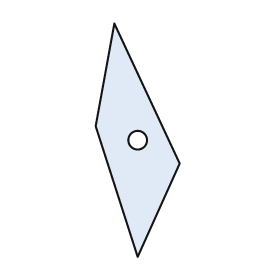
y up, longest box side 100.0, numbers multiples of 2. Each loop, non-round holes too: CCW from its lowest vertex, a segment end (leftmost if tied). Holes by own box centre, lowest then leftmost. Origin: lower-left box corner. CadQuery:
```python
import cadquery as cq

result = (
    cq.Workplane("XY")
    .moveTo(18.0, 0.0)
    .lineTo(36.0, 40.0)
    .lineTo(8.0, 100.0)
    .lineTo(0.0, 56.0)
    .close()
    .moveTo(18.0, 50.0)
    .circle(4.0)
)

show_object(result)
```